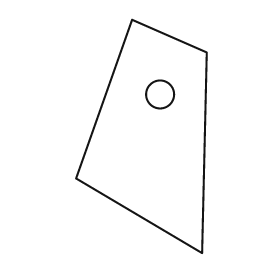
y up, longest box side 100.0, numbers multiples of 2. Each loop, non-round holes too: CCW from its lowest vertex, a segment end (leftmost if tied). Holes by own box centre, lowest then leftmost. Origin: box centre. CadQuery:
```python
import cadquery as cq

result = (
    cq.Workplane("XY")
    .moveTo(26.0, -50.0)
    .lineTo(28.0, 36.0)
    .lineTo(-4.0, 50.0)
    .lineTo(-28.0, -18.0)
    .close()
    .moveTo(8.0, 18.0)
    .circle(6.0)
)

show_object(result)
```